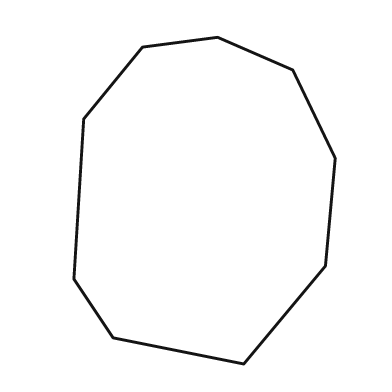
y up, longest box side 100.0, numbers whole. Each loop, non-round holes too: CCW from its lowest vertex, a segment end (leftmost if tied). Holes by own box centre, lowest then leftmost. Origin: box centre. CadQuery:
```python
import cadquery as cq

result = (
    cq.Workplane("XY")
    .moveTo(12.0, -50.0)
    .lineTo(37.0, -20.0)
    .lineTo(40.0, 13.0)
    .lineTo(27.0, 40.0)
    .lineTo(4.0, 50.0)
    .lineTo(-19.0, 47.0)
    .lineTo(-37.0, 25.0)
    .lineTo(-40.0, -24.0)
    .lineTo(-28.0, -42.0)
    .close()
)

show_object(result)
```